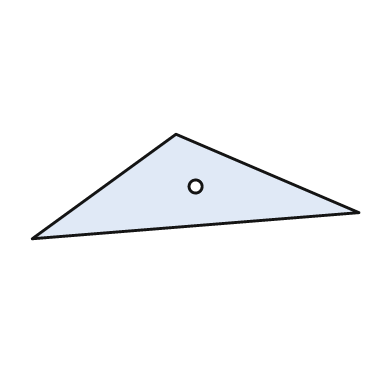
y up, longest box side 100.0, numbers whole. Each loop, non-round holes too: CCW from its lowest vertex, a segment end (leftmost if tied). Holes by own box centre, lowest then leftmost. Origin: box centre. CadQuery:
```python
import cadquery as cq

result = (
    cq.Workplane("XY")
    .moveTo(-50.0, -16.0)
    .lineTo(50.0, -8.0)
    .lineTo(-6.0, 16.0)
    .close()
    .moveTo(0.0, 0.0)
    .circle(2.0)
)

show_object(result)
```